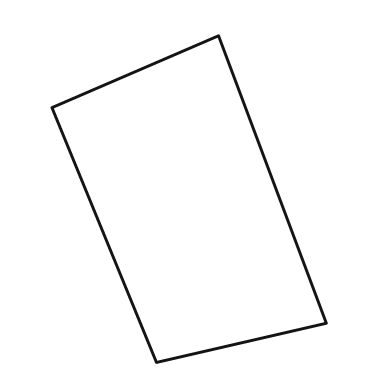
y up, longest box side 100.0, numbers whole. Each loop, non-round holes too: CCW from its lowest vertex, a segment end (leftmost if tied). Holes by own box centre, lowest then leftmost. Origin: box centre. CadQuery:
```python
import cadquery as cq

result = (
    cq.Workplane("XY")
    .moveTo(-10.0, -50.0)
    .lineTo(42.0, -38.0)
    .lineTo(9.0, 50.0)
    .lineTo(-42.0, 28.0)
    .close()
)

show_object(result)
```